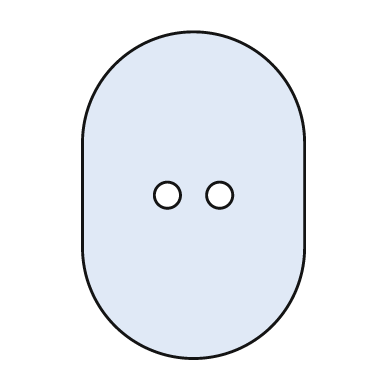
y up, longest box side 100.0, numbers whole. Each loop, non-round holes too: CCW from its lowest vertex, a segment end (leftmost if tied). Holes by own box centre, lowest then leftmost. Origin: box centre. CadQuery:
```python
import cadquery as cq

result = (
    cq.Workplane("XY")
    .moveTo(-34.0, -16.0)
    .threePointArc((0.0, -50.0), (34.0, -16.0))
    .lineTo(34.0, 16.0)
    .threePointArc((0.0, 50.0), (-34.0, 16.0))
    .close()
    .moveTo(-8.0, 0.0)
    .circle(4.0)
    .moveTo(8.0, 0.0)
    .circle(4.0)
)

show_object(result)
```